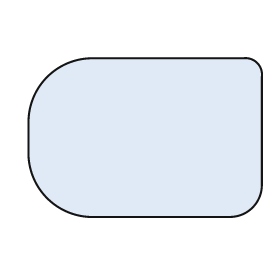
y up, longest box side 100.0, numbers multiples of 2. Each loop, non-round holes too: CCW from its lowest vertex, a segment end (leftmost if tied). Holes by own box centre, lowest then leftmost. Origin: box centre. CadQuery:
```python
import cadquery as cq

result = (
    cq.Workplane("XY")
    .moveTo(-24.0, -34.0)
    .lineTo(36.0, -34.0)
    .threePointArc((46.0, -30.0), (50.0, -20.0))
    .lineTo(50.0, 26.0)
    .threePointArc((48.0, 32.0), (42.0, 34.0))
    .lineTo(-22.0, 34.0)
    .threePointArc((-42.0, 26.0), (-50.0, 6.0))
    .lineTo(-50.0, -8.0)
    .threePointArc((-42.0, -26.0), (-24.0, -34.0))
    .close()
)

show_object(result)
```